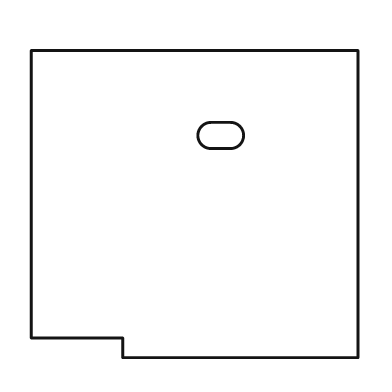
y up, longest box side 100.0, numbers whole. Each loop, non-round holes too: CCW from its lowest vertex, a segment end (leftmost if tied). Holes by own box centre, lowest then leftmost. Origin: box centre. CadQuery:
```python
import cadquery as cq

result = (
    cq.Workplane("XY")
    .moveTo(-22.0, -47.0)
    .lineTo(50.0, -47.0)
    .lineTo(50.0, 47.0)
    .lineTo(-50.0, 47.0)
    .lineTo(-50.0, -41.0)
    .lineTo(-22.0, -41.0)
    .close()
    .moveTo(5.0, 17.0)
    .lineTo(11.0, 17.0)
    .threePointArc((15.0, 21.0), (11.0, 25.0))
    .lineTo(5.0, 25.0)
    .threePointArc((1.0, 21.0), (5.0, 17.0))
    .close()
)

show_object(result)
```